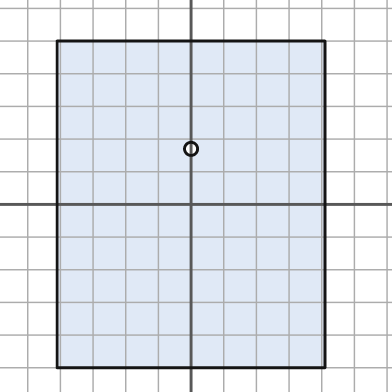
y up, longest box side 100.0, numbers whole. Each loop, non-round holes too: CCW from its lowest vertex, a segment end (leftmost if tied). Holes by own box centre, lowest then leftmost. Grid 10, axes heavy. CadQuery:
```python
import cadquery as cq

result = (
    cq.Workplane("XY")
    .moveTo(-41.0, -50.0)
    .lineTo(41.0, -50.0)
    .lineTo(41.0, 50.0)
    .lineTo(-41.0, 50.0)
    .close()
    .moveTo(0.0, 17.0)
    .circle(2.0)
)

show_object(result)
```